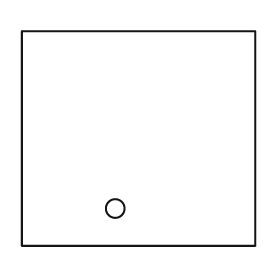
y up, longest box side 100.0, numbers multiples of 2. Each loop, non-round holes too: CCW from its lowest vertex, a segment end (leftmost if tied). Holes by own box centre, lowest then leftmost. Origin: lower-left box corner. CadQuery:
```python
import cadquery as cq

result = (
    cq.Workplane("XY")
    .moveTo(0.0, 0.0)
    .lineTo(100.0, 0.0)
    .lineTo(100.0, 92.0)
    .lineTo(0.0, 92.0)
    .close()
    .moveTo(40.0, 16.0)
    .circle(4.0)
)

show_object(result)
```